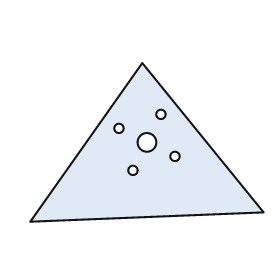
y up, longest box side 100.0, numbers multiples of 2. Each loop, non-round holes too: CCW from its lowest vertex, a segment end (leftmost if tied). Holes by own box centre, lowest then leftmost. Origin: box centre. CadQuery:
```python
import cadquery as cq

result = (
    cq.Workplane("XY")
    .moveTo(-50.0, -34.0)
    .lineTo(50.0, -30.0)
    .lineTo(-2.0, 34.0)
    .close()
    .moveTo(-6.0, -12.0)
    .circle(2.0)
    .moveTo(12.0, -6.0)
    .circle(2.0)
    .moveTo(0.0, 0.0)
    .circle(4.0)
    .moveTo(-12.0, 6.0)
    .circle(2.0)
    .moveTo(6.0, 12.0)
    .circle(2.0)
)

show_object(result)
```